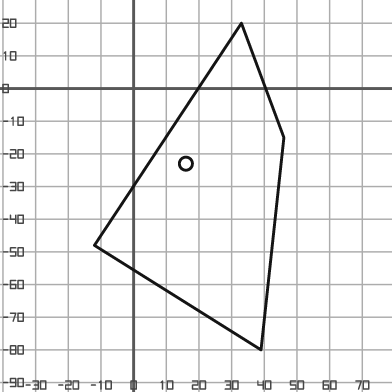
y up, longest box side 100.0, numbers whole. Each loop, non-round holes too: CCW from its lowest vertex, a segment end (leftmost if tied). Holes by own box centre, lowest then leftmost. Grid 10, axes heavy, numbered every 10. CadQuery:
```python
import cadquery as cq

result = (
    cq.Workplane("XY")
    .moveTo(39.0, -80.0)
    .lineTo(46.0, -15.0)
    .lineTo(33.0, 20.0)
    .lineTo(-12.0, -48.0)
    .close()
    .moveTo(16.0, -23.0)
    .circle(2.0)
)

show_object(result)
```